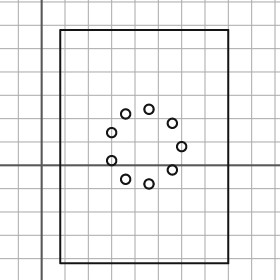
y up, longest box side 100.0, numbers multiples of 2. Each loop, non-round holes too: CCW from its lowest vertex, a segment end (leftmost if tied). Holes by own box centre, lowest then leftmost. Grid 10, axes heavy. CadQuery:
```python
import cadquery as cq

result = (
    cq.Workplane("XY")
    .moveTo(8.0, -42.0)
    .lineTo(80.0, -42.0)
    .lineTo(80.0, 58.0)
    .lineTo(8.0, 58.0)
    .close()
    .moveTo(46.0, -8.0)
    .circle(2.0)
    .moveTo(36.0, -6.0)
    .circle(2.0)
    .moveTo(56.0, -2.0)
    .circle(2.0)
    .moveTo(30.0, 2.0)
    .circle(2.0)
    .moveTo(60.0, 8.0)
    .circle(2.0)
    .moveTo(30.0, 14.0)
    .circle(2.0)
    .moveTo(56.0, 18.0)
    .circle(2.0)
    .moveTo(36.0, 22.0)
    .circle(2.0)
    .moveTo(46.0, 24.0)
    .circle(2.0)
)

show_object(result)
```